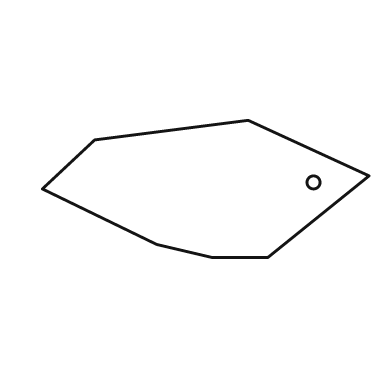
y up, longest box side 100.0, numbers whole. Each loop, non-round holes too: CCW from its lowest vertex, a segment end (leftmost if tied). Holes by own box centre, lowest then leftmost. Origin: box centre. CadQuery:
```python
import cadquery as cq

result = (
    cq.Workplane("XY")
    .moveTo(2.0, -21.0)
    .lineTo(19.0, -21.0)
    .lineTo(50.0, 4.0)
    .lineTo(13.0, 21.0)
    .lineTo(-34.0, 15.0)
    .lineTo(-50.0, 0.0)
    .lineTo(-15.0, -17.0)
    .close()
    .moveTo(33.0, 2.0)
    .circle(2.0)
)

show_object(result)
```